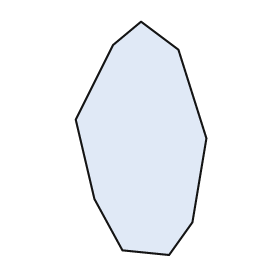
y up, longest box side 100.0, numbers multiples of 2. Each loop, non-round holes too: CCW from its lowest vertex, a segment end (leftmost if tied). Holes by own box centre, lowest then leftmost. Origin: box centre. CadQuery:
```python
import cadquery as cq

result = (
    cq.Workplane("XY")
    .moveTo(12.0, -50.0)
    .lineTo(22.0, -36.0)
    .lineTo(28.0, 0.0)
    .lineTo(16.0, 38.0)
    .lineTo(0.0, 50.0)
    .lineTo(-12.0, 40.0)
    .lineTo(-28.0, 8.0)
    .lineTo(-20.0, -26.0)
    .lineTo(-8.0, -48.0)
    .close()
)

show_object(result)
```